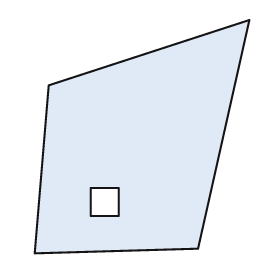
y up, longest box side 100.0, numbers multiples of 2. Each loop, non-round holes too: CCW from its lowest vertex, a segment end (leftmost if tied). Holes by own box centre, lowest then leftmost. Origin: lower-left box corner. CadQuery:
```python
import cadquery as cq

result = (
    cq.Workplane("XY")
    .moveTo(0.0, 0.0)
    .lineTo(70.0, 2.0)
    .lineTo(92.0, 100.0)
    .lineTo(6.0, 72.0)
    .close()
    .moveTo(24.0, 16.0)
    .lineTo(36.0, 16.0)
    .lineTo(36.0, 28.0)
    .lineTo(24.0, 28.0)
    .close()
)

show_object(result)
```